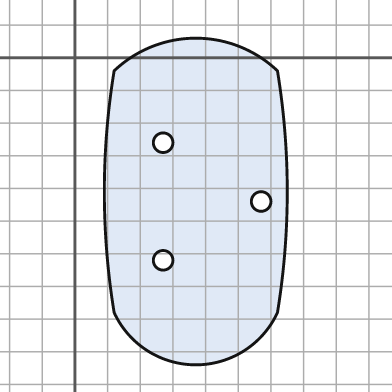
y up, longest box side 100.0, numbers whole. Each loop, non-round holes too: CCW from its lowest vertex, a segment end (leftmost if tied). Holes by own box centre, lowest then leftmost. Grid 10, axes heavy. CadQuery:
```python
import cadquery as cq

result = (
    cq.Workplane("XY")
    .moveTo(12.0, -78.0)
    .threePointArc((37.0, -94.0), (62.0, -78.0))
    .threePointArc((65.0, -41.0), (62.0, -4.0))
    .threePointArc((37.0, 6.0), (12.0, -4.0))
    .threePointArc((9.0, -41.0), (12.0, -78.0))
    .close()
    .moveTo(27.0, -62.0)
    .circle(3.0)
    .moveTo(57.0, -44.0)
    .circle(3.0)
    .moveTo(27.0, -26.0)
    .circle(3.0)
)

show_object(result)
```